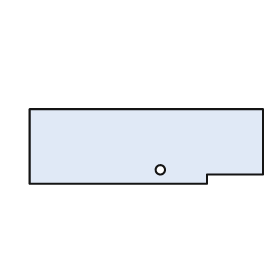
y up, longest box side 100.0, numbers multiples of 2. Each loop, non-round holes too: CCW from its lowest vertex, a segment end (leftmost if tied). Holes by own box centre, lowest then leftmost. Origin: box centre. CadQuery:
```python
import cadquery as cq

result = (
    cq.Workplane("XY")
    .moveTo(-50.0, -16.0)
    .lineTo(26.0, -16.0)
    .lineTo(26.0, -12.0)
    .lineTo(50.0, -12.0)
    .lineTo(50.0, 16.0)
    .lineTo(-50.0, 16.0)
    .close()
    .moveTo(6.0, -10.0)
    .circle(2.0)
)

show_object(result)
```